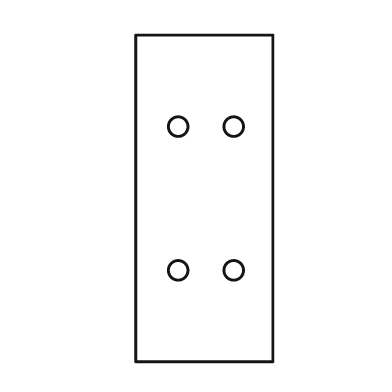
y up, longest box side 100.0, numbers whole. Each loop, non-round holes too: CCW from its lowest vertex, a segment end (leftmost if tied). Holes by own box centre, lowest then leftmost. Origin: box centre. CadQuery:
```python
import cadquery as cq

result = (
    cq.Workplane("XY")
    .moveTo(-21.0, -50.0)
    .lineTo(21.0, -50.0)
    .lineTo(21.0, 50.0)
    .lineTo(-21.0, 50.0)
    .close()
    .moveTo(-8.0, -22.0)
    .circle(3.0)
    .moveTo(9.0, -22.0)
    .circle(3.0)
    .moveTo(-8.0, 22.0)
    .circle(3.0)
    .moveTo(9.0, 22.0)
    .circle(3.0)
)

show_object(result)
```